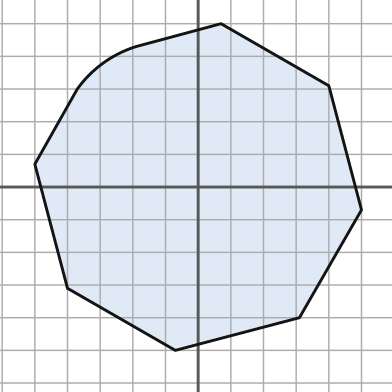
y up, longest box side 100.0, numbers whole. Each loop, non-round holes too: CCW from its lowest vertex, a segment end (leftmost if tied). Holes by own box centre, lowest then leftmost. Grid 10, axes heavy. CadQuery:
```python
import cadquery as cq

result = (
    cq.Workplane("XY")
    .moveTo(-7.0, -50.0)
    .lineTo(31.0, -40.0)
    .lineTo(50.0, -7.0)
    .lineTo(40.0, 31.0)
    .lineTo(7.0, 50.0)
    .lineTo(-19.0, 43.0)
    .threePointArc((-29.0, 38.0), (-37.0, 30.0))
    .lineTo(-50.0, 7.0)
    .lineTo(-40.0, -31.0)
    .close()
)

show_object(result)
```